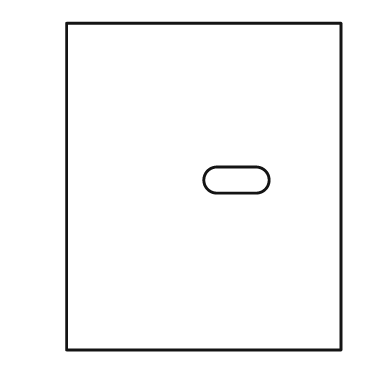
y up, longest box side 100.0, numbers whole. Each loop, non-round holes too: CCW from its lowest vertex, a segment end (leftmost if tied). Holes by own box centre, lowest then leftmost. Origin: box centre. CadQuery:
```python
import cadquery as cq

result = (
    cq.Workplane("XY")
    .moveTo(-42.0, -50.0)
    .lineTo(42.0, -50.0)
    .lineTo(42.0, 50.0)
    .lineTo(-42.0, 50.0)
    .close()
    .moveTo(4.0, -2.0)
    .lineTo(16.0, -2.0)
    .threePointArc((20.0, 2.0), (16.0, 6.0))
    .lineTo(4.0, 6.0)
    .threePointArc((0.0, 2.0), (4.0, -2.0))
    .close()
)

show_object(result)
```